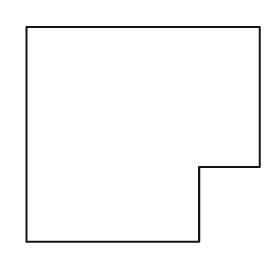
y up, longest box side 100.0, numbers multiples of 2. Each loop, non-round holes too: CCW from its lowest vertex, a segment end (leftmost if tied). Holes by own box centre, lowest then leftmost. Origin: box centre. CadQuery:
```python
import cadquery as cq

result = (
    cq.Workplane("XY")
    .moveTo(-50.0, -46.0)
    .lineTo(24.0, -46.0)
    .lineTo(24.0, -14.0)
    .lineTo(50.0, -14.0)
    .lineTo(50.0, 46.0)
    .lineTo(-50.0, 46.0)
    .close()
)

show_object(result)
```